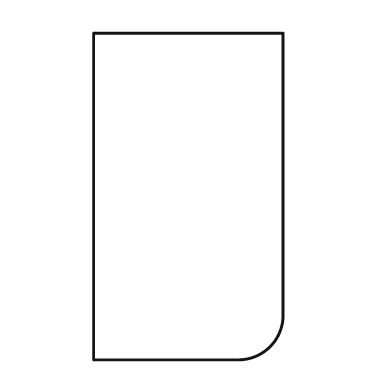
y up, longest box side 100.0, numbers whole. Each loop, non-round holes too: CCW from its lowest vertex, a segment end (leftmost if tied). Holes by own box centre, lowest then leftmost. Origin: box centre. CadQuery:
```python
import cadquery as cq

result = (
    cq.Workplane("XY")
    .moveTo(-29.0, -50.0)
    .lineTo(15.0, -50.0)
    .threePointArc((25.0, -46.0), (29.0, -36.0))
    .lineTo(29.0, 50.0)
    .lineTo(-29.0, 50.0)
    .close()
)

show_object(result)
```